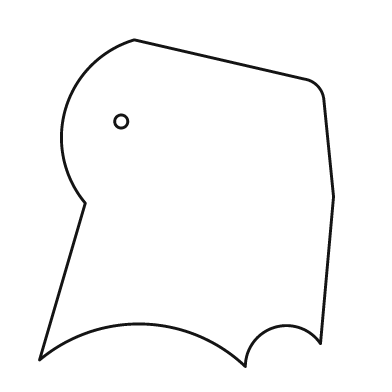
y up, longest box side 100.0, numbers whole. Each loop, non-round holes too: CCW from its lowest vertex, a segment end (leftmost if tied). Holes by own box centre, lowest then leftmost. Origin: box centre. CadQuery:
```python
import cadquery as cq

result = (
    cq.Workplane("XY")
    .moveTo(18.0, -50.0)
    .threePointArc((27.0, -38.0), (41.0, -43.0))
    .lineTo(45.0, 2.0)
    .lineTo(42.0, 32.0)
    .threePointArc((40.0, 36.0), (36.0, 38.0))
    .lineTo(-16.0, 50.0)
    .threePointArc((-37.0, 29.0), (-31.0, 0.0))
    .lineTo(-45.0, -48.0)
    .threePointArc((-13.0, -37.0), (18.0, -50.0))
    .close()
    .moveTo(-20.0, 25.0)
    .circle(2.0)
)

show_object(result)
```